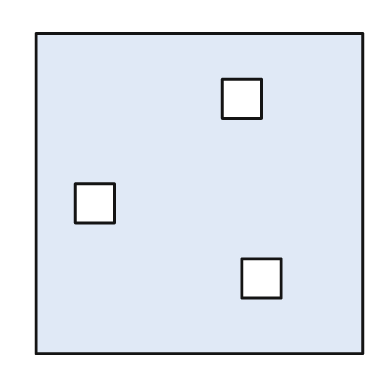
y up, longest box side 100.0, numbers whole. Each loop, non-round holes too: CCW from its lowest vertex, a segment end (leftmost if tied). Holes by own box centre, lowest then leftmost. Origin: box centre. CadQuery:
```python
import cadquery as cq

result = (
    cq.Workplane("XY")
    .moveTo(-50.0, -49.0)
    .lineTo(50.0, -49.0)
    .lineTo(50.0, 49.0)
    .lineTo(-50.0, 49.0)
    .close()
    .moveTo(13.0, -32.0)
    .lineTo(25.0, -32.0)
    .lineTo(25.0, -20.0)
    .lineTo(13.0, -20.0)
    .close()
    .moveTo(-38.0, -9.0)
    .lineTo(-26.0, -9.0)
    .lineTo(-26.0, 3.0)
    .lineTo(-38.0, 3.0)
    .close()
    .moveTo(7.0, 23.0)
    .lineTo(19.0, 23.0)
    .lineTo(19.0, 35.0)
    .lineTo(7.0, 35.0)
    .close()
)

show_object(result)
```